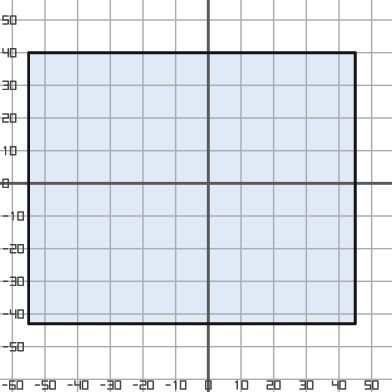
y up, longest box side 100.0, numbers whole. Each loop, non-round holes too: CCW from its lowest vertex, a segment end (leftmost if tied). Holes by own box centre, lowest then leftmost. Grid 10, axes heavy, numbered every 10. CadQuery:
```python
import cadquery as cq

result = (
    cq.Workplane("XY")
    .moveTo(-55.0, -43.0)
    .lineTo(45.0, -43.0)
    .lineTo(45.0, 40.0)
    .lineTo(-55.0, 40.0)
    .close()
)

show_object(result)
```